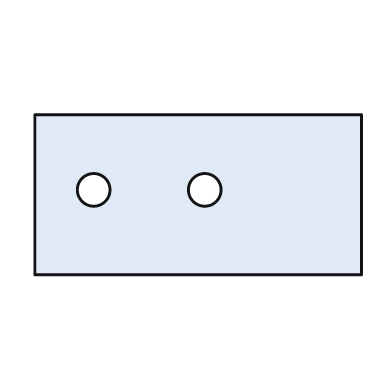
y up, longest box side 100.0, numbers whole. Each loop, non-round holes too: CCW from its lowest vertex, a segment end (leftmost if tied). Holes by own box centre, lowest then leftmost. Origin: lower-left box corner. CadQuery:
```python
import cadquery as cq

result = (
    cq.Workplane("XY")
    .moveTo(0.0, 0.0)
    .lineTo(100.0, 0.0)
    .lineTo(100.0, 49.0)
    .lineTo(0.0, 49.0)
    .close()
    .moveTo(18.0, 26.0)
    .circle(5.0)
    .moveTo(52.0, 26.0)
    .circle(5.0)
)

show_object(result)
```